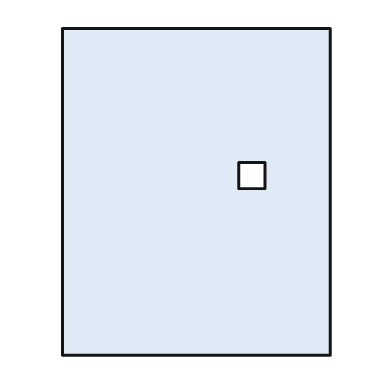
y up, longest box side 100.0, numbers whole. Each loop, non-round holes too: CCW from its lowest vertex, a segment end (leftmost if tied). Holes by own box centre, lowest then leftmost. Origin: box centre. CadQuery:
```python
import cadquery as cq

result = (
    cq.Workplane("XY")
    .moveTo(-41.0, -50.0)
    .lineTo(41.0, -50.0)
    .lineTo(41.0, 50.0)
    .lineTo(-41.0, 50.0)
    .close()
    .moveTo(13.0, 1.0)
    .lineTo(21.0, 1.0)
    .lineTo(21.0, 9.0)
    .lineTo(13.0, 9.0)
    .close()
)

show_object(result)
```